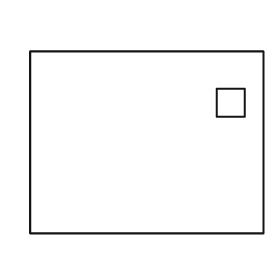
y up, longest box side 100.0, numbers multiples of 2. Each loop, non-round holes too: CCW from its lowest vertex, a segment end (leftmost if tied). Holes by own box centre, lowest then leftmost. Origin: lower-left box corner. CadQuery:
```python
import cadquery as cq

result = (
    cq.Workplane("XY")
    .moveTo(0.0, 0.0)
    .lineTo(100.0, 0.0)
    .lineTo(100.0, 78.0)
    .lineTo(0.0, 78.0)
    .close()
    .moveTo(80.0, 50.0)
    .lineTo(92.0, 50.0)
    .lineTo(92.0, 62.0)
    .lineTo(80.0, 62.0)
    .close()
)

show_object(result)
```